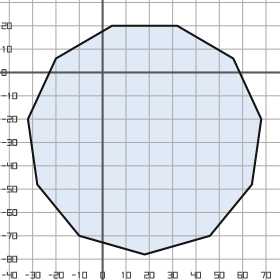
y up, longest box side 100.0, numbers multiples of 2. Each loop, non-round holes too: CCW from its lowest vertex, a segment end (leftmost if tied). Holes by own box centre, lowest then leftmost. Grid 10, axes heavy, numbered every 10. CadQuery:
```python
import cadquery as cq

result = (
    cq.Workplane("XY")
    .moveTo(18.0, -78.0)
    .lineTo(46.0, -70.0)
    .lineTo(64.0, -48.0)
    .lineTo(68.0, -20.0)
    .lineTo(56.0, 6.0)
    .lineTo(32.0, 20.0)
    .lineTo(4.0, 20.0)
    .lineTo(-20.0, 6.0)
    .lineTo(-32.0, -20.0)
    .lineTo(-28.0, -48.0)
    .lineTo(-10.0, -70.0)
    .close()
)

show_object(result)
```